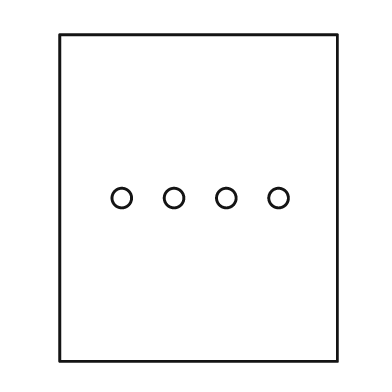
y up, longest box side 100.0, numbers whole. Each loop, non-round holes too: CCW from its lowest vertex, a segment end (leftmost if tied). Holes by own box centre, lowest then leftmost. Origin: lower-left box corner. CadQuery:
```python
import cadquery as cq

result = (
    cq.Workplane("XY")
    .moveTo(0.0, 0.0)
    .lineTo(85.0, 0.0)
    .lineTo(85.0, 100.0)
    .lineTo(0.0, 100.0)
    .close()
    .moveTo(19.0, 50.0)
    .circle(3.0)
    .moveTo(35.0, 50.0)
    .circle(3.0)
    .moveTo(51.0, 50.0)
    .circle(3.0)
    .moveTo(67.0, 50.0)
    .circle(3.0)
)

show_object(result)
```